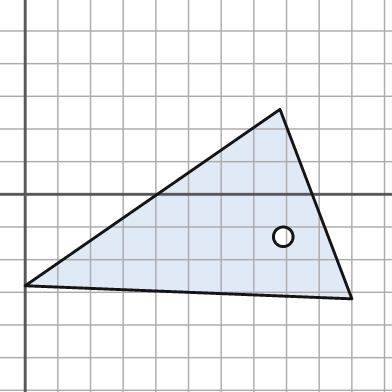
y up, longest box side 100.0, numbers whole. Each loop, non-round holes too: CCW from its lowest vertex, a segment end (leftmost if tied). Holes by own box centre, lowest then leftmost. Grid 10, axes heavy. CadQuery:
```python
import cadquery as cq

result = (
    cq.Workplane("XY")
    .moveTo(100.0, -32.0)
    .lineTo(78.0, 26.0)
    .lineTo(0.0, -28.0)
    .close()
    .moveTo(79.0, -13.0)
    .circle(3.0)
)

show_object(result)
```